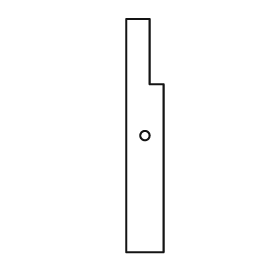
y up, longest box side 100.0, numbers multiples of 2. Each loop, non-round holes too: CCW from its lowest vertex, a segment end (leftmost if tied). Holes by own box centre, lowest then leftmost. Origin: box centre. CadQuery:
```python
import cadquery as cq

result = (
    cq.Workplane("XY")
    .moveTo(-8.0, -50.0)
    .lineTo(8.0, -50.0)
    .lineTo(8.0, 22.0)
    .lineTo(2.0, 22.0)
    .lineTo(2.0, 50.0)
    .lineTo(-8.0, 50.0)
    .close()
    .moveTo(0.0, 0.0)
    .circle(2.0)
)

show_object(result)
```